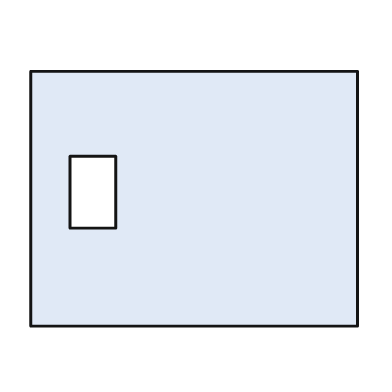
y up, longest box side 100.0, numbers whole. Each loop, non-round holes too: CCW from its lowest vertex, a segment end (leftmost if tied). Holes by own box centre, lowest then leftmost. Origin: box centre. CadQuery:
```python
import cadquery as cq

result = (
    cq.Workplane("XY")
    .moveTo(-50.0, -39.0)
    .lineTo(50.0, -39.0)
    .lineTo(50.0, 39.0)
    .lineTo(-50.0, 39.0)
    .close()
    .moveTo(-38.0, -9.0)
    .lineTo(-24.0, -9.0)
    .lineTo(-24.0, 13.0)
    .lineTo(-38.0, 13.0)
    .close()
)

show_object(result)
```